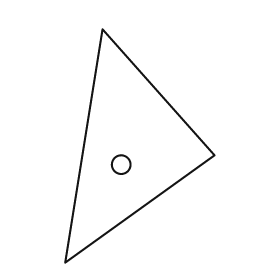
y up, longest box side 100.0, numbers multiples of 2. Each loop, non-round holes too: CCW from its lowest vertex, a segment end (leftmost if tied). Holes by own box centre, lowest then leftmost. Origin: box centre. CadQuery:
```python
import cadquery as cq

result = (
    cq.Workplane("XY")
    .moveTo(-32.0, -50.0)
    .lineTo(32.0, -4.0)
    .lineTo(-16.0, 50.0)
    .close()
    .moveTo(-8.0, -8.0)
    .circle(4.0)
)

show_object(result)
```